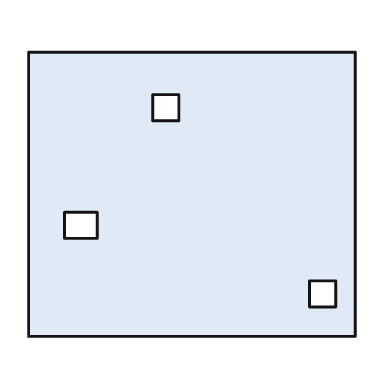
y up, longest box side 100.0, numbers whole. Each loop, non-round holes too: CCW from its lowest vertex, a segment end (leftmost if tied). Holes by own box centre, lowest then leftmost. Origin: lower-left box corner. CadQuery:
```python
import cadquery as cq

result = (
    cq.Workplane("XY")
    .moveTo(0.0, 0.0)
    .lineTo(100.0, 0.0)
    .lineTo(100.0, 87.0)
    .lineTo(0.0, 87.0)
    .close()
    .moveTo(86.0, 9.0)
    .lineTo(94.0, 9.0)
    .lineTo(94.0, 17.0)
    .lineTo(86.0, 17.0)
    .close()
    .moveTo(11.0, 30.0)
    .lineTo(21.0, 30.0)
    .lineTo(21.0, 38.0)
    .lineTo(11.0, 38.0)
    .close()
    .moveTo(38.0, 66.0)
    .lineTo(46.0, 66.0)
    .lineTo(46.0, 74.0)
    .lineTo(38.0, 74.0)
    .close()
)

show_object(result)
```